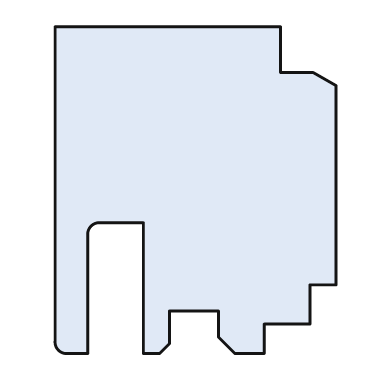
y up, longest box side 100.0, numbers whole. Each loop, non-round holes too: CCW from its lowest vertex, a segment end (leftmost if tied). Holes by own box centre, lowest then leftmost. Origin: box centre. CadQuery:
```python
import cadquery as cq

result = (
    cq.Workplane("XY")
    .moveTo(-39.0, -50.0)
    .lineTo(-33.0, -50.0)
    .lineTo(-33.0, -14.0)
    .threePointArc((-32.0, -11.0), (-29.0, -10.0))
    .lineTo(-16.0, -10.0)
    .lineTo(-16.0, -50.0)
    .lineTo(-11.0, -50.0)
    .lineTo(-8.0, -47.0)
    .lineTo(-8.0, -37.0)
    .lineTo(7.0, -37.0)
    .lineTo(7.0, -45.0)
    .lineTo(12.0, -50.0)
    .lineTo(21.0, -50.0)
    .lineTo(21.0, -41.0)
    .lineTo(35.0, -41.0)
    .lineTo(35.0, -29.0)
    .lineTo(43.0, -29.0)
    .lineTo(43.0, 32.0)
    .lineTo(36.0, 36.0)
    .lineTo(26.0, 36.0)
    .lineTo(26.0, 50.0)
    .lineTo(-43.0, 50.0)
    .lineTo(-43.0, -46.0)
    .threePointArc((-42.0, -49.0), (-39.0, -50.0))
    .close()
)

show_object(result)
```